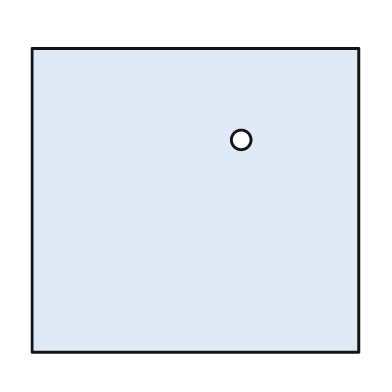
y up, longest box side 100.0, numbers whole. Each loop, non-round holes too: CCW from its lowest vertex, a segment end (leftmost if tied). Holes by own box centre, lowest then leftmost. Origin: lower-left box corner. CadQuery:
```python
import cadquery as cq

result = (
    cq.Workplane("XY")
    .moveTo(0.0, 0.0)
    .lineTo(100.0, 0.0)
    .lineTo(100.0, 93.0)
    .lineTo(0.0, 93.0)
    .close()
    .moveTo(64.0, 65.0)
    .circle(3.0)
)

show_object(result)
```